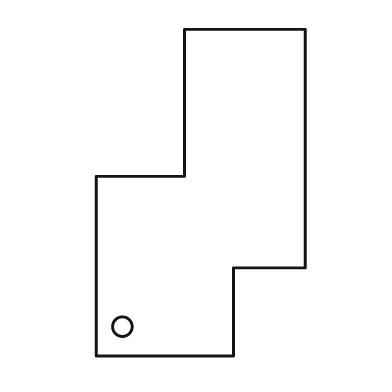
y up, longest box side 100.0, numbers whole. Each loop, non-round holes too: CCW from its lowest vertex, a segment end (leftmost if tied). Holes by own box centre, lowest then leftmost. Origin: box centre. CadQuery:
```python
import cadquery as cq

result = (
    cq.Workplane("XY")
    .moveTo(-32.0, -50.0)
    .lineTo(10.0, -50.0)
    .lineTo(10.0, -23.0)
    .lineTo(32.0, -23.0)
    .lineTo(32.0, 50.0)
    .lineTo(-5.0, 50.0)
    .lineTo(-5.0, 5.0)
    .lineTo(-32.0, 5.0)
    .close()
    .moveTo(-24.0, -41.0)
    .circle(3.0)
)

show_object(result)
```